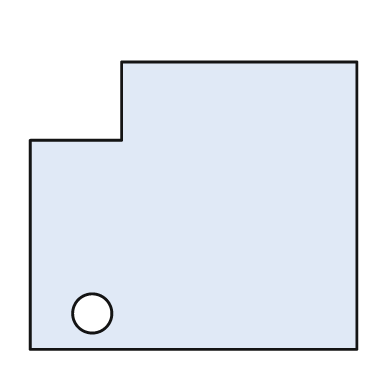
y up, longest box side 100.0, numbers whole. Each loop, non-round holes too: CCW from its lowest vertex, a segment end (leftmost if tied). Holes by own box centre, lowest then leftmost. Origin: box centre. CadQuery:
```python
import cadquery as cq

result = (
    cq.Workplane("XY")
    .moveTo(-50.0, -44.0)
    .lineTo(50.0, -44.0)
    .lineTo(50.0, 44.0)
    .lineTo(-22.0, 44.0)
    .lineTo(-22.0, 20.0)
    .lineTo(-50.0, 20.0)
    .close()
    .moveTo(-31.0, -33.0)
    .circle(6.0)
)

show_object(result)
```